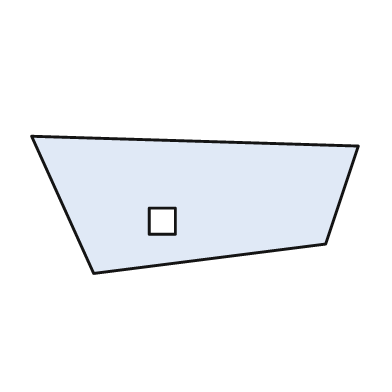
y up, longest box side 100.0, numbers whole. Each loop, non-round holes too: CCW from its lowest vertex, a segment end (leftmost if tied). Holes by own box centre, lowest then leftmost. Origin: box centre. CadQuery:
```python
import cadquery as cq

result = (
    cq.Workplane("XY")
    .moveTo(-31.0, -21.0)
    .lineTo(40.0, -12.0)
    .lineTo(50.0, 18.0)
    .lineTo(-50.0, 21.0)
    .close()
    .moveTo(-14.0, -9.0)
    .lineTo(-6.0, -9.0)
    .lineTo(-6.0, -1.0)
    .lineTo(-14.0, -1.0)
    .close()
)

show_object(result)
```